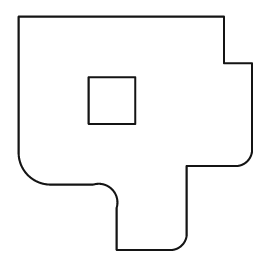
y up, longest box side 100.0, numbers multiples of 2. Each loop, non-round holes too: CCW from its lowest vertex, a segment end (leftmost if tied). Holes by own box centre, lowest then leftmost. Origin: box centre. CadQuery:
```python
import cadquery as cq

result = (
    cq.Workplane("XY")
    .moveTo(-8.0, -50.0)
    .lineTo(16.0, -50.0)
    .threePointArc((20.0, -48.0), (22.0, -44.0))
    .lineTo(22.0, -14.0)
    .lineTo(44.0, -14.0)
    .threePointArc((48.0, -12.0), (50.0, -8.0))
    .lineTo(50.0, 30.0)
    .lineTo(38.0, 30.0)
    .lineTo(38.0, 50.0)
    .lineTo(-50.0, 50.0)
    .lineTo(-50.0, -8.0)
    .threePointArc((-46.0, -18.0), (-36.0, -22.0))
    .lineTo(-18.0, -22.0)
    .threePointArc((-10.0, -24.0), (-8.0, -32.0))
    .close()
    .moveTo(-20.0, 4.0)
    .lineTo(0.0, 4.0)
    .lineTo(0.0, 24.0)
    .lineTo(-20.0, 24.0)
    .close()
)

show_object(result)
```